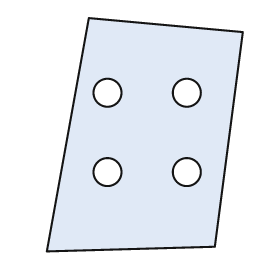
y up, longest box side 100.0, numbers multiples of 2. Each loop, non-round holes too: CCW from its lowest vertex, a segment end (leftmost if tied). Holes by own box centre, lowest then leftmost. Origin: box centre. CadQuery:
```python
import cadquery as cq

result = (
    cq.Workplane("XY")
    .moveTo(-42.0, -50.0)
    .lineTo(30.0, -48.0)
    .lineTo(42.0, 44.0)
    .lineTo(-24.0, 50.0)
    .close()
    .moveTo(-16.0, -16.0)
    .circle(6.0)
    .moveTo(18.0, -16.0)
    .circle(6.0)
    .moveTo(-16.0, 18.0)
    .circle(6.0)
    .moveTo(18.0, 18.0)
    .circle(6.0)
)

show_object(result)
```